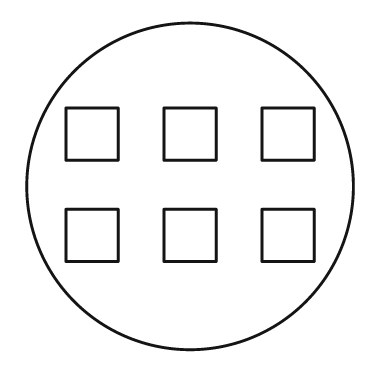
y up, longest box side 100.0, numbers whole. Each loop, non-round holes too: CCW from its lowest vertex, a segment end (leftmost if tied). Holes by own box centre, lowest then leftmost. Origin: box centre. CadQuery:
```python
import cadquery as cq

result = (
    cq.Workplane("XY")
    .moveTo(0.0, 0.0)
    .circle(50.0)
    .moveTo(-38.0, -23.0)
    .lineTo(-22.0, -23.0)
    .lineTo(-22.0, -7.0)
    .lineTo(-38.0, -7.0)
    .close()
    .moveTo(-8.0, -23.0)
    .lineTo(8.0, -23.0)
    .lineTo(8.0, -7.0)
    .lineTo(-8.0, -7.0)
    .close()
    .moveTo(22.0, -23.0)
    .lineTo(38.0, -23.0)
    .lineTo(38.0, -7.0)
    .lineTo(22.0, -7.0)
    .close()
    .moveTo(-38.0, 8.0)
    .lineTo(-22.0, 8.0)
    .lineTo(-22.0, 24.0)
    .lineTo(-38.0, 24.0)
    .close()
    .moveTo(-8.0, 8.0)
    .lineTo(8.0, 8.0)
    .lineTo(8.0, 24.0)
    .lineTo(-8.0, 24.0)
    .close()
    .moveTo(22.0, 8.0)
    .lineTo(38.0, 8.0)
    .lineTo(38.0, 24.0)
    .lineTo(22.0, 24.0)
    .close()
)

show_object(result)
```